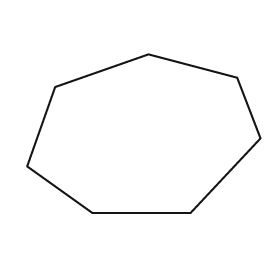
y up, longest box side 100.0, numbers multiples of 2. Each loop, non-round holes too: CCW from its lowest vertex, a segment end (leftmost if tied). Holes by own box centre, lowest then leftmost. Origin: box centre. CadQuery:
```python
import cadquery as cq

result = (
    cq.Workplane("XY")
    .moveTo(-22.0, -34.0)
    .lineTo(20.0, -34.0)
    .lineTo(50.0, -2.0)
    .lineTo(40.0, 24.0)
    .lineTo(2.0, 34.0)
    .lineTo(-38.0, 20.0)
    .lineTo(-50.0, -14.0)
    .close()
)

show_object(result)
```